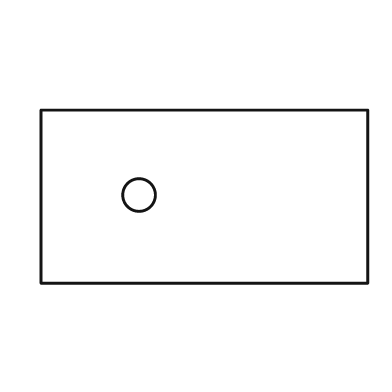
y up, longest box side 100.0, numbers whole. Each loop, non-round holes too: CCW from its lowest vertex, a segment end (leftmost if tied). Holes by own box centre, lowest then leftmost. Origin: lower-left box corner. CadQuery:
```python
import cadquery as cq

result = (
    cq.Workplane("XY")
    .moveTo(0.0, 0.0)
    .lineTo(100.0, 0.0)
    .lineTo(100.0, 53.0)
    .lineTo(0.0, 53.0)
    .close()
    .moveTo(30.0, 27.0)
    .circle(5.0)
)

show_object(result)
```